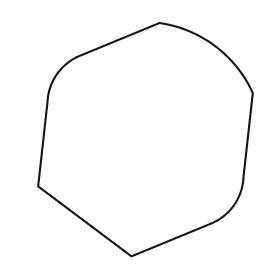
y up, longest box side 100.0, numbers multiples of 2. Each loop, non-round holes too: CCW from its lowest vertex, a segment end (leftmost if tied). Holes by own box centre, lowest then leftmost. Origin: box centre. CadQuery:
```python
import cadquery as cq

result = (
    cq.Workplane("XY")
    .moveTo(-6.0, -50.0)
    .lineTo(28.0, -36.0)
    .threePointArc((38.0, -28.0), (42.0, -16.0))
    .lineTo(46.0, 20.0)
    .threePointArc((30.0, 40.0), (6.0, 50.0))
    .lineTo(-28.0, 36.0)
    .threePointArc((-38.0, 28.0), (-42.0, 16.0))
    .lineTo(-46.0, -20.0)
    .close()
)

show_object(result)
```